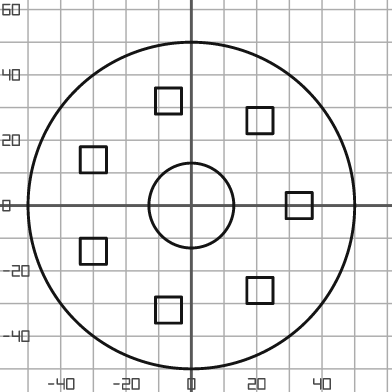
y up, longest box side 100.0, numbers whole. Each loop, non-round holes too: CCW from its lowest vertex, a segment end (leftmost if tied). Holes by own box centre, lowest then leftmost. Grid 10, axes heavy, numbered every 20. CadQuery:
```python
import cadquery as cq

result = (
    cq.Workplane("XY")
    .moveTo(0.0, 0.0)
    .circle(50.0)
    .moveTo(-11.0, -36.0)
    .lineTo(-3.0, -36.0)
    .lineTo(-3.0, -28.0)
    .lineTo(-11.0, -28.0)
    .close()
    .moveTo(17.0, -30.0)
    .lineTo(25.0, -30.0)
    .lineTo(25.0, -22.0)
    .lineTo(17.0, -22.0)
    .close()
    .moveTo(-34.0, -18.0)
    .lineTo(-26.0, -18.0)
    .lineTo(-26.0, -10.0)
    .lineTo(-34.0, -10.0)
    .close()
    .moveTo(0.0, 0.0)
    .circle(13.0)
    .moveTo(29.0, -4.0)
    .lineTo(37.0, -4.0)
    .lineTo(37.0, 4.0)
    .lineTo(29.0, 4.0)
    .close()
    .moveTo(-34.0, 10.0)
    .lineTo(-26.0, 10.0)
    .lineTo(-26.0, 18.0)
    .lineTo(-34.0, 18.0)
    .close()
    .moveTo(17.0, 22.0)
    .lineTo(25.0, 22.0)
    .lineTo(25.0, 30.0)
    .lineTo(17.0, 30.0)
    .close()
    .moveTo(-11.0, 28.0)
    .lineTo(-3.0, 28.0)
    .lineTo(-3.0, 36.0)
    .lineTo(-11.0, 36.0)
    .close()
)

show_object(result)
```